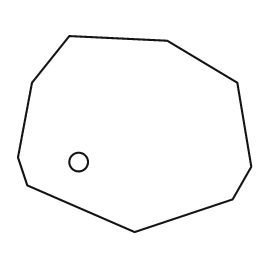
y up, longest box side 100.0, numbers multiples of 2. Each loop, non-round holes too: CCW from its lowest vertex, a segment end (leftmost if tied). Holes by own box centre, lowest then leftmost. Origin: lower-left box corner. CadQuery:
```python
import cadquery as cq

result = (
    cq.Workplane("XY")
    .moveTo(50.0, 0.0)
    .lineTo(92.0, 14.0)
    .lineTo(100.0, 28.0)
    .lineTo(94.0, 64.0)
    .lineTo(64.0, 82.0)
    .lineTo(22.0, 84.0)
    .lineTo(6.0, 64.0)
    .lineTo(0.0, 32.0)
    .lineTo(4.0, 20.0)
    .close()
    .moveTo(26.0, 30.0)
    .circle(4.0)
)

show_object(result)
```